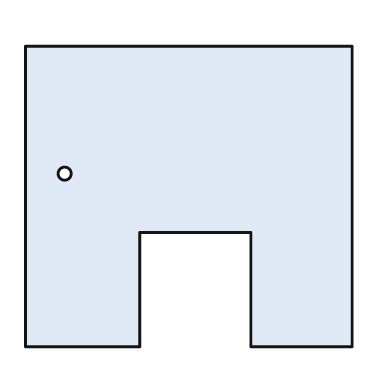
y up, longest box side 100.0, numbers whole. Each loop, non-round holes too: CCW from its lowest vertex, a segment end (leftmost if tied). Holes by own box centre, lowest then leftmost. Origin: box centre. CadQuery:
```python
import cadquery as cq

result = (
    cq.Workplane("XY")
    .moveTo(-50.0, -46.0)
    .lineTo(-15.0, -46.0)
    .lineTo(-15.0, -11.0)
    .lineTo(19.0, -11.0)
    .lineTo(19.0, -46.0)
    .lineTo(50.0, -46.0)
    .lineTo(50.0, 46.0)
    .lineTo(-50.0, 46.0)
    .close()
    .moveTo(-38.0, 7.0)
    .circle(2.0)
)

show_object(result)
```